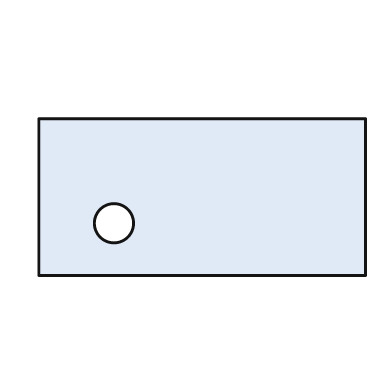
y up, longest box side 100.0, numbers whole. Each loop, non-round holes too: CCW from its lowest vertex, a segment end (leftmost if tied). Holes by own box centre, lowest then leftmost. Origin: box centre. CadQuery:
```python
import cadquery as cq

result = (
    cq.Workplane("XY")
    .moveTo(-50.0, -24.0)
    .lineTo(50.0, -24.0)
    .lineTo(50.0, 24.0)
    .lineTo(-50.0, 24.0)
    .close()
    .moveTo(-27.0, -8.0)
    .circle(6.0)
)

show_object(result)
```